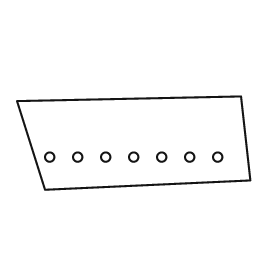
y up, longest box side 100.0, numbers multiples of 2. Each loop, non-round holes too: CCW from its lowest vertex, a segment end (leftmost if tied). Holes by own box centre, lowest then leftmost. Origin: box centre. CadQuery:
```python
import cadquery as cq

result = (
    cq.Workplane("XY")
    .moveTo(-38.0, -20.0)
    .lineTo(50.0, -16.0)
    .lineTo(46.0, 20.0)
    .lineTo(-50.0, 18.0)
    .close()
    .moveTo(-36.0, -6.0)
    .circle(2.0)
    .moveTo(-24.0, -6.0)
    .circle(2.0)
    .moveTo(-12.0, -6.0)
    .circle(2.0)
    .moveTo(0.0, -6.0)
    .circle(2.0)
    .moveTo(12.0, -6.0)
    .circle(2.0)
    .moveTo(24.0, -6.0)
    .circle(2.0)
    .moveTo(36.0, -6.0)
    .circle(2.0)
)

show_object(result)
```